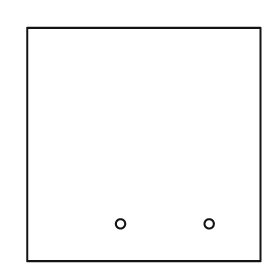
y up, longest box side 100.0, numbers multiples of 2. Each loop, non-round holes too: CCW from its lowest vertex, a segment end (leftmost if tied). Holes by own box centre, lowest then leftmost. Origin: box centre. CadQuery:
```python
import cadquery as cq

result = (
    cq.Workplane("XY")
    .moveTo(-50.0, -50.0)
    .lineTo(50.0, -50.0)
    .lineTo(50.0, 50.0)
    .lineTo(-50.0, 50.0)
    .close()
    .moveTo(-10.0, -34.0)
    .circle(2.0)
    .moveTo(28.0, -34.0)
    .circle(2.0)
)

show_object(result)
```